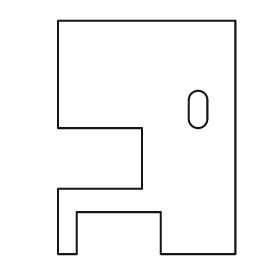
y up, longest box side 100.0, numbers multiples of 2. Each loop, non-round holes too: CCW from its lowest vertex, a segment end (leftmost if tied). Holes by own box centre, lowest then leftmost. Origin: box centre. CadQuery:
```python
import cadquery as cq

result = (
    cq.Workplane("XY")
    .moveTo(-38.0, -50.0)
    .lineTo(-30.0, -50.0)
    .lineTo(-30.0, -32.0)
    .lineTo(6.0, -32.0)
    .lineTo(6.0, -50.0)
    .lineTo(38.0, -50.0)
    .lineTo(38.0, 50.0)
    .lineTo(-38.0, 50.0)
    .lineTo(-38.0, 4.0)
    .lineTo(-2.0, 4.0)
    .lineTo(-2.0, -22.0)
    .lineTo(-38.0, -22.0)
    .close()
    .moveTo(18.0, 8.0)
    .threePointArc((22.0, 4.0), (26.0, 8.0))
    .lineTo(26.0, 16.0)
    .threePointArc((22.0, 20.0), (18.0, 16.0))
    .close()
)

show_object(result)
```